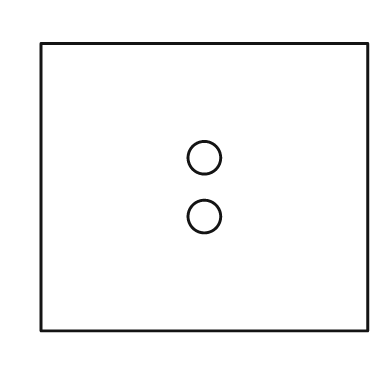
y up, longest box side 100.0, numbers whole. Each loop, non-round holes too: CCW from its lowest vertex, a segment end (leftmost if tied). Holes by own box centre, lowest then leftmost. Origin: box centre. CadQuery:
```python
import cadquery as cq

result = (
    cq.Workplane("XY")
    .moveTo(-50.0, -44.0)
    .lineTo(50.0, -44.0)
    .lineTo(50.0, 44.0)
    .lineTo(-50.0, 44.0)
    .close()
    .moveTo(0.0, -9.0)
    .circle(5.0)
    .moveTo(0.0, 9.0)
    .circle(5.0)
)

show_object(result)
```